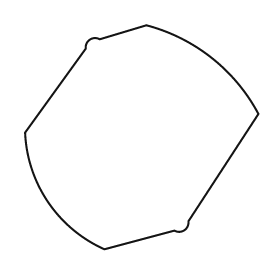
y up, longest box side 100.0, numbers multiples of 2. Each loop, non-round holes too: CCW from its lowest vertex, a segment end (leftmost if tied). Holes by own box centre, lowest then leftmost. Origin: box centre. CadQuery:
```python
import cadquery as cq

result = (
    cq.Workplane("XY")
    .moveTo(-16.0, -48.0)
    .lineTo(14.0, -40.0)
    .threePointArc((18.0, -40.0), (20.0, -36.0))
    .lineTo(50.0, 10.0)
    .threePointArc((30.0, 34.0), (2.0, 48.0))
    .lineTo(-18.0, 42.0)
    .threePointArc((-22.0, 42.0), (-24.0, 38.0))
    .lineTo(-50.0, 2.0)
    .threePointArc((-40.0, -28.0), (-16.0, -48.0))
    .close()
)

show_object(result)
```